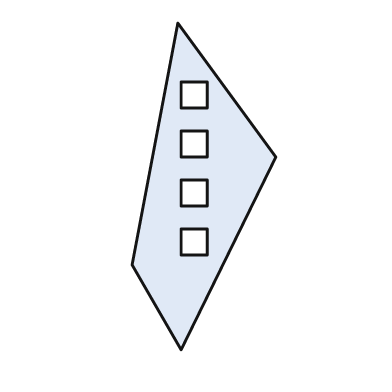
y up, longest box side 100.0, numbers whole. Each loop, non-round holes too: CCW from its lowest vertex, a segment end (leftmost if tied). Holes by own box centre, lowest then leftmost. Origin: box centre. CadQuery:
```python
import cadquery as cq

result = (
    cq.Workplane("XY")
    .moveTo(-7.0, -50.0)
    .lineTo(22.0, 9.0)
    .lineTo(-8.0, 50.0)
    .lineTo(-22.0, -24.0)
    .close()
    .moveTo(-7.0, -21.0)
    .lineTo(1.0, -21.0)
    .lineTo(1.0, -13.0)
    .lineTo(-7.0, -13.0)
    .close()
    .moveTo(-7.0, -6.0)
    .lineTo(1.0, -6.0)
    .lineTo(1.0, 2.0)
    .lineTo(-7.0, 2.0)
    .close()
    .moveTo(-7.0, 9.0)
    .lineTo(1.0, 9.0)
    .lineTo(1.0, 17.0)
    .lineTo(-7.0, 17.0)
    .close()
    .moveTo(-7.0, 24.0)
    .lineTo(1.0, 24.0)
    .lineTo(1.0, 32.0)
    .lineTo(-7.0, 32.0)
    .close()
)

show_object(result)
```